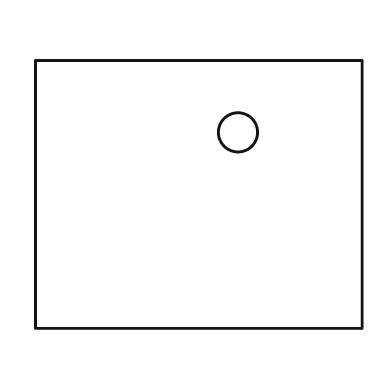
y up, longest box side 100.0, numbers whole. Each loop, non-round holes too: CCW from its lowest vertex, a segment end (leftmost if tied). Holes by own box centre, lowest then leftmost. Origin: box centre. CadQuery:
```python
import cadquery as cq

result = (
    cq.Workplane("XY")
    .moveTo(-50.0, -41.0)
    .lineTo(50.0, -41.0)
    .lineTo(50.0, 41.0)
    .lineTo(-50.0, 41.0)
    .close()
    .moveTo(12.0, 19.0)
    .circle(6.0)
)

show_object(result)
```